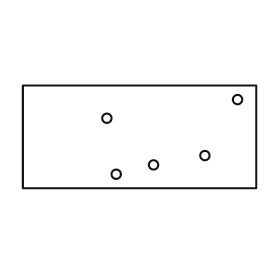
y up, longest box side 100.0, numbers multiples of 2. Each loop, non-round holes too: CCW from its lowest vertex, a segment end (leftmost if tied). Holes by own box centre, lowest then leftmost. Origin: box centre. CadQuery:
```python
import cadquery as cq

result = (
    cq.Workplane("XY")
    .moveTo(-50.0, -22.0)
    .lineTo(50.0, -22.0)
    .lineTo(50.0, 22.0)
    .lineTo(-50.0, 22.0)
    .close()
    .moveTo(-10.0, -16.0)
    .circle(2.0)
    .moveTo(6.0, -12.0)
    .circle(2.0)
    .moveTo(28.0, -8.0)
    .circle(2.0)
    .moveTo(-14.0, 8.0)
    .circle(2.0)
    .moveTo(42.0, 16.0)
    .circle(2.0)
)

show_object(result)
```